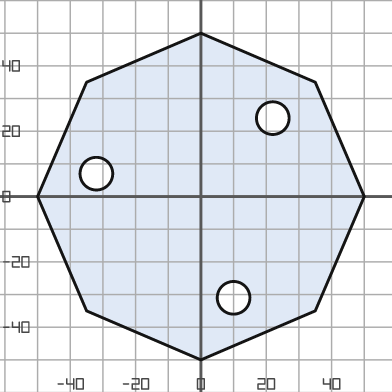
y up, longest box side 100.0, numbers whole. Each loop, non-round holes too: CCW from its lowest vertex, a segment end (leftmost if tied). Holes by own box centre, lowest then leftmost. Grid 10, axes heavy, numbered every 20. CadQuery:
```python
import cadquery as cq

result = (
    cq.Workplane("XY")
    .moveTo(0.0, -50.0)
    .lineTo(35.0, -35.0)
    .lineTo(50.0, 0.0)
    .lineTo(35.0, 35.0)
    .lineTo(0.0, 50.0)
    .lineTo(-35.0, 35.0)
    .lineTo(-50.0, 0.0)
    .lineTo(-35.0, -35.0)
    .close()
    .moveTo(10.0, -31.0)
    .circle(5.0)
    .moveTo(-32.0, 7.0)
    .circle(5.0)
    .moveTo(22.0, 24.0)
    .circle(5.0)
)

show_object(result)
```